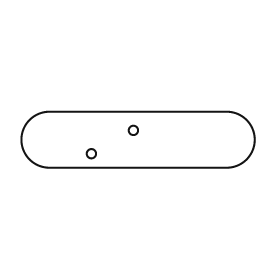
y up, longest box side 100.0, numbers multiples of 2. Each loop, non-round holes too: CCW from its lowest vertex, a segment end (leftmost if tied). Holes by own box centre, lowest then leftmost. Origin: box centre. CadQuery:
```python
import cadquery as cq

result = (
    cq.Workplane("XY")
    .moveTo(-38.0, -12.0)
    .lineTo(38.0, -12.0)
    .threePointArc((50.0, 0.0), (38.0, 12.0))
    .lineTo(-38.0, 12.0)
    .threePointArc((-50.0, 0.0), (-38.0, -12.0))
    .close()
    .moveTo(-20.0, -6.0)
    .circle(2.0)
    .moveTo(-2.0, 4.0)
    .circle(2.0)
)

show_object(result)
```